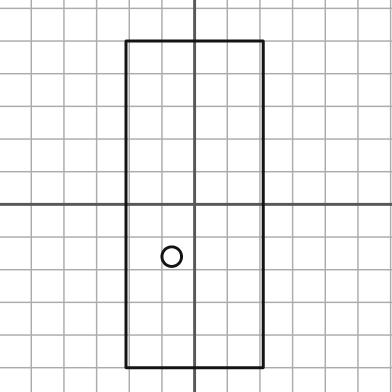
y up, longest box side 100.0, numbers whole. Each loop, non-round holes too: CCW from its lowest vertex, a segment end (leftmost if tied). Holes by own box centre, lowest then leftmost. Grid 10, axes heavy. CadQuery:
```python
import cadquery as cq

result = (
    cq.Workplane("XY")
    .moveTo(-21.0, -50.0)
    .lineTo(21.0, -50.0)
    .lineTo(21.0, 50.0)
    .lineTo(-21.0, 50.0)
    .close()
    .moveTo(-7.0, -16.0)
    .circle(3.0)
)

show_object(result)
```